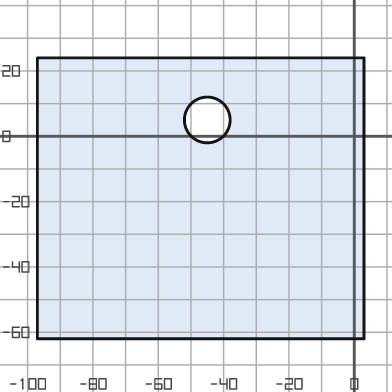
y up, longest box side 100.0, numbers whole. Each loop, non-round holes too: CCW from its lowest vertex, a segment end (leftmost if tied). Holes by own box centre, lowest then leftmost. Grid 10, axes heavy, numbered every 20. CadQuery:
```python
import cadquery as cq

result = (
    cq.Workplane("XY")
    .moveTo(-97.0, -62.0)
    .lineTo(3.0, -62.0)
    .lineTo(3.0, 24.0)
    .lineTo(-97.0, 24.0)
    .close()
    .moveTo(-45.0, 5.0)
    .circle(7.0)
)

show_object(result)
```